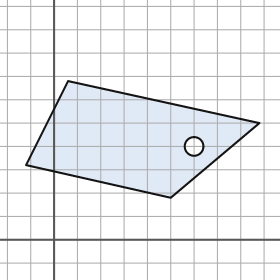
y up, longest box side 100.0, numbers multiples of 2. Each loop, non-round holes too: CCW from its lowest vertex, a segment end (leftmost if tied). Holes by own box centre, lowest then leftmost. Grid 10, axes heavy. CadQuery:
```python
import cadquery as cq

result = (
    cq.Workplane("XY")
    .moveTo(50.0, 18.0)
    .lineTo(88.0, 50.0)
    .lineTo(6.0, 68.0)
    .lineTo(-12.0, 32.0)
    .close()
    .moveTo(60.0, 40.0)
    .circle(4.0)
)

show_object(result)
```